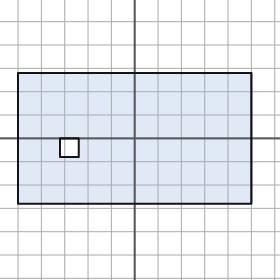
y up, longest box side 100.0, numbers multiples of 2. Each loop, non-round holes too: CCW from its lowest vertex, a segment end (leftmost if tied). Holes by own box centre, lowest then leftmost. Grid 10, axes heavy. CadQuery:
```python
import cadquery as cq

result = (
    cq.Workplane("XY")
    .moveTo(-50.0, -28.0)
    .lineTo(50.0, -28.0)
    .lineTo(50.0, 28.0)
    .lineTo(-50.0, 28.0)
    .close()
    .moveTo(-32.0, -8.0)
    .lineTo(-24.0, -8.0)
    .lineTo(-24.0, 0.0)
    .lineTo(-32.0, 0.0)
    .close()
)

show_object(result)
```